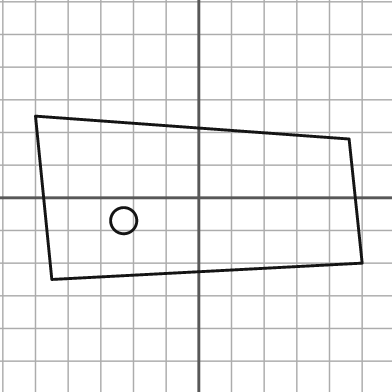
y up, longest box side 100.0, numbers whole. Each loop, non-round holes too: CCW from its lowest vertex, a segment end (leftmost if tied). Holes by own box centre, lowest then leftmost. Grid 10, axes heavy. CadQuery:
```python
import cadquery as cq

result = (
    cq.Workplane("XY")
    .moveTo(-45.0, -25.0)
    .lineTo(50.0, -20.0)
    .lineTo(46.0, 18.0)
    .lineTo(-50.0, 25.0)
    .close()
    .moveTo(-23.0, -7.0)
    .circle(4.0)
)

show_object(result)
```